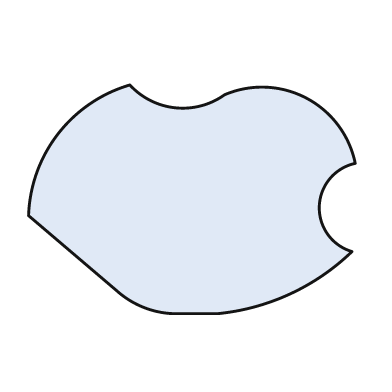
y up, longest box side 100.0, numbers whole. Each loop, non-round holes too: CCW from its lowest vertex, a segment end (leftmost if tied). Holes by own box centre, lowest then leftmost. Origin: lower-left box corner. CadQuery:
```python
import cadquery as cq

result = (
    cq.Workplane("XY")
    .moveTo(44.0, 0.0)
    .lineTo(58.0, 0.0)
    .threePointArc((80.0, 6.0), (99.0, 19.0))
    .threePointArc((89.0, 33.0), (100.0, 46.0))
    .threePointArc((85.0, 66.0), (60.0, 67.0))
    .threePointArc((45.0, 63.0), (31.0, 70.0))
    .threePointArc((9.0, 55.0), (0.0, 30.0))
    .lineTo(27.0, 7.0)
    .threePointArc((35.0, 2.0), (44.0, 0.0))
    .close()
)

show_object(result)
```